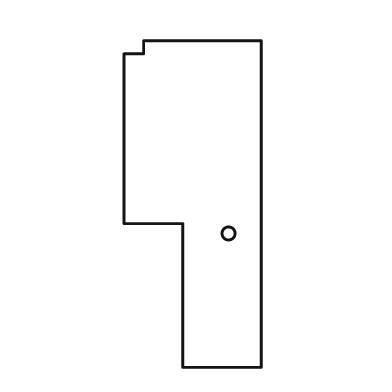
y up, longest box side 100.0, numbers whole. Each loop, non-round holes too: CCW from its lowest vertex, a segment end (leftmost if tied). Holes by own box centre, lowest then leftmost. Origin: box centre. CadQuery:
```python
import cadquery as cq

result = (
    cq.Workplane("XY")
    .moveTo(-3.0, -50.0)
    .lineTo(21.0, -50.0)
    .lineTo(21.0, 50.0)
    .lineTo(-15.0, 50.0)
    .lineTo(-15.0, 46.0)
    .lineTo(-21.0, 46.0)
    .lineTo(-21.0, -6.0)
    .lineTo(-3.0, -6.0)
    .close()
    .moveTo(11.0, -9.0)
    .circle(2.0)
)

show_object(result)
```